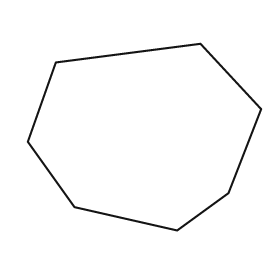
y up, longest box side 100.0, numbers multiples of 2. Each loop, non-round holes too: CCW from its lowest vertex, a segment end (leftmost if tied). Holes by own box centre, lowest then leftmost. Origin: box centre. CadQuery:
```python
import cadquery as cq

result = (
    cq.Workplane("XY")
    .moveTo(14.0, -40.0)
    .lineTo(36.0, -24.0)
    .lineTo(50.0, 12.0)
    .lineTo(24.0, 40.0)
    .lineTo(-38.0, 32.0)
    .lineTo(-50.0, -2.0)
    .lineTo(-30.0, -30.0)
    .close()
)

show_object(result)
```